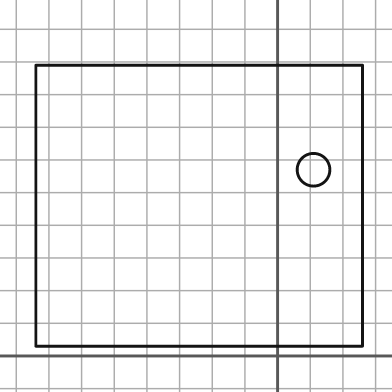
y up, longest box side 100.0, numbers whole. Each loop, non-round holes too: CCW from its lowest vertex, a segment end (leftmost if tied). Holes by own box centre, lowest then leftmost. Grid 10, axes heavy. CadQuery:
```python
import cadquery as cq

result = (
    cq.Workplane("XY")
    .moveTo(-74.0, 3.0)
    .lineTo(26.0, 3.0)
    .lineTo(26.0, 89.0)
    .lineTo(-74.0, 89.0)
    .close()
    .moveTo(11.0, 57.0)
    .circle(5.0)
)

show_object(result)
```